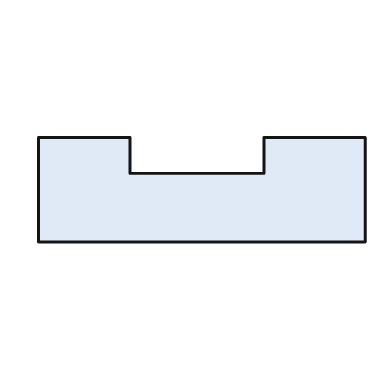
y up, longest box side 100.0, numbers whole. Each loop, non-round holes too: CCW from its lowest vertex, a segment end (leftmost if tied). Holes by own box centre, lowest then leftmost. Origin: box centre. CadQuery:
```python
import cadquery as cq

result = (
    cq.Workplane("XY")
    .moveTo(-50.0, -16.0)
    .lineTo(50.0, -16.0)
    .lineTo(50.0, 16.0)
    .lineTo(19.0, 16.0)
    .lineTo(19.0, 5.0)
    .lineTo(-22.0, 5.0)
    .lineTo(-22.0, 16.0)
    .lineTo(-50.0, 16.0)
    .close()
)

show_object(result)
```